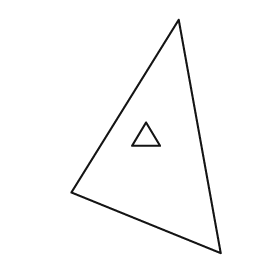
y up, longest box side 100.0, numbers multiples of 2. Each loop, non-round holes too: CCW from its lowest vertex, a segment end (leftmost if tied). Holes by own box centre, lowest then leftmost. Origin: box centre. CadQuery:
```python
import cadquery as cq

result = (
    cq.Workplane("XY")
    .moveTo(32.0, -50.0)
    .lineTo(14.0, 50.0)
    .lineTo(-32.0, -24.0)
    .close()
    .moveTo(-6.0, -4.0)
    .lineTo(6.0, -4.0)
    .lineTo(0.0, 6.0)
    .close()
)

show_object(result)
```